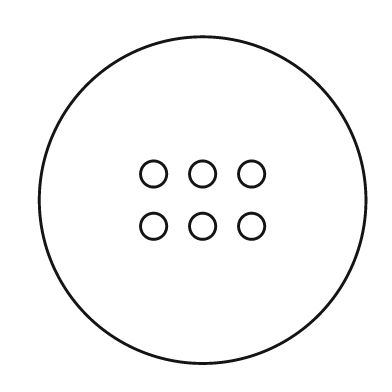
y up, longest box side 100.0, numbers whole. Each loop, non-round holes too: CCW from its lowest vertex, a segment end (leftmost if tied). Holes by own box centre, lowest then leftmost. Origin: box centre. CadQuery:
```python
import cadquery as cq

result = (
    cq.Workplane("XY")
    .moveTo(0.0, 0.0)
    .circle(50.0)
    .moveTo(-15.0, -8.0)
    .circle(4.0)
    .moveTo(0.0, -8.0)
    .circle(4.0)
    .moveTo(15.0, -8.0)
    .circle(4.0)
    .moveTo(-15.0, 8.0)
    .circle(4.0)
    .moveTo(0.0, 8.0)
    .circle(4.0)
    .moveTo(15.0, 8.0)
    .circle(4.0)
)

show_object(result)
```